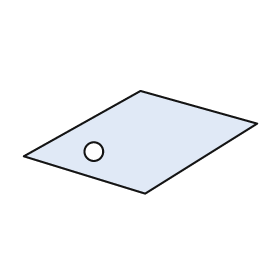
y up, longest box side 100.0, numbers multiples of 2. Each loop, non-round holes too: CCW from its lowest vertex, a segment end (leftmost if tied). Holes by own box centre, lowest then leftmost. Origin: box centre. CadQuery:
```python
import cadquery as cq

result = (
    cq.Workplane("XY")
    .moveTo(2.0, -22.0)
    .lineTo(50.0, 8.0)
    .lineTo(0.0, 22.0)
    .lineTo(-50.0, -6.0)
    .close()
    .moveTo(-20.0, -4.0)
    .circle(4.0)
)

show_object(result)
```